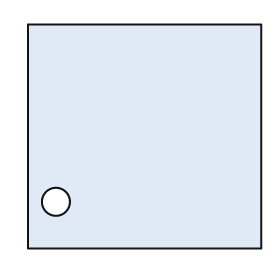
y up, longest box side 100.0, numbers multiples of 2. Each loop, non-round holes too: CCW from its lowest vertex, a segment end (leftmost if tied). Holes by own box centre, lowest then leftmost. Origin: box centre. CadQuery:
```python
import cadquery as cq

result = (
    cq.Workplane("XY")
    .moveTo(-50.0, -48.0)
    .lineTo(50.0, -48.0)
    .lineTo(50.0, 48.0)
    .lineTo(-50.0, 48.0)
    .close()
    .moveTo(-38.0, -28.0)
    .circle(6.0)
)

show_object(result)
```